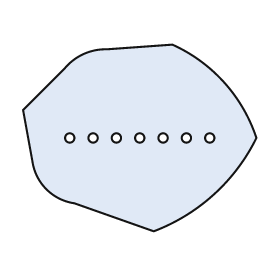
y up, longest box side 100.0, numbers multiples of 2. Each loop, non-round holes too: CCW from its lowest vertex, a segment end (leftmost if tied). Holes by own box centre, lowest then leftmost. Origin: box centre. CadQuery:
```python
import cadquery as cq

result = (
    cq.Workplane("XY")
    .moveTo(6.0, -40.0)
    .threePointArc((32.0, -24.0), (50.0, 0.0))
    .threePointArc((36.0, 24.0), (14.0, 40.0))
    .lineTo(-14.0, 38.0)
    .threePointArc((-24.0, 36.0), (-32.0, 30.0))
    .lineTo(-50.0, 12.0)
    .lineTo(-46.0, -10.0)
    .threePointArc((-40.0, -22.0), (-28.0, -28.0))
    .close()
    .moveTo(-30.0, 0.0)
    .circle(2.0)
    .moveTo(-20.0, 0.0)
    .circle(2.0)
    .moveTo(-10.0, 0.0)
    .circle(2.0)
    .moveTo(0.0, 0.0)
    .circle(2.0)
    .moveTo(10.0, 0.0)
    .circle(2.0)
    .moveTo(20.0, 0.0)
    .circle(2.0)
    .moveTo(30.0, 0.0)
    .circle(2.0)
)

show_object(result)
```